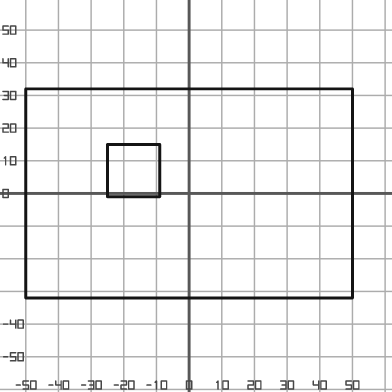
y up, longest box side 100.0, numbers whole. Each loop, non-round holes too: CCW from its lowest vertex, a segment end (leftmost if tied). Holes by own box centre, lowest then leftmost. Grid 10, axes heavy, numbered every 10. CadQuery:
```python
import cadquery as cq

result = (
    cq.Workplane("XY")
    .moveTo(-50.0, -32.0)
    .lineTo(50.0, -32.0)
    .lineTo(50.0, 32.0)
    .lineTo(-50.0, 32.0)
    .close()
    .moveTo(-25.0, -1.0)
    .lineTo(-9.0, -1.0)
    .lineTo(-9.0, 15.0)
    .lineTo(-25.0, 15.0)
    .close()
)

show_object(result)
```